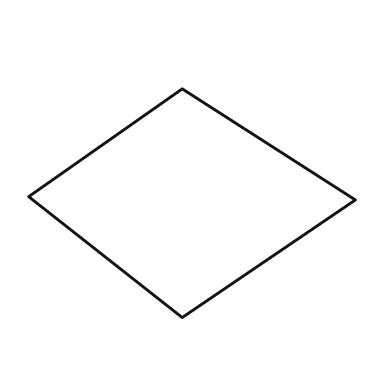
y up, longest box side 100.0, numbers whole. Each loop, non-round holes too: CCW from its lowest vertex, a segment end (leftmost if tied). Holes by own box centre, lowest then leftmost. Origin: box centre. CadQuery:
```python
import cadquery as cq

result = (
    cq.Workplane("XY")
    .moveTo(-3.0, -35.0)
    .lineTo(50.0, 1.0)
    .lineTo(-3.0, 35.0)
    .lineTo(-50.0, 2.0)
    .close()
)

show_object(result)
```